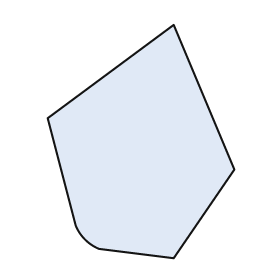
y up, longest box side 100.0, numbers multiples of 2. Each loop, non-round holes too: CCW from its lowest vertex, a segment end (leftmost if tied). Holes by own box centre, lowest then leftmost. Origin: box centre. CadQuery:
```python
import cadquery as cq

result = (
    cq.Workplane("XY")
    .moveTo(14.0, -50.0)
    .lineTo(40.0, -12.0)
    .lineTo(14.0, 50.0)
    .lineTo(-40.0, 10.0)
    .lineTo(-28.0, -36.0)
    .threePointArc((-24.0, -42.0), (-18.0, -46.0))
    .close()
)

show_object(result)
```